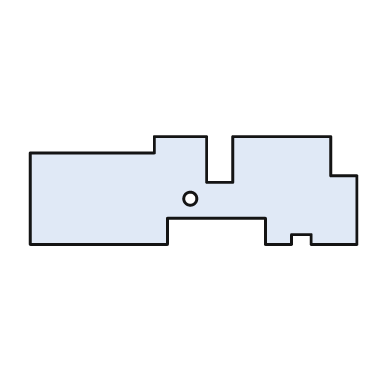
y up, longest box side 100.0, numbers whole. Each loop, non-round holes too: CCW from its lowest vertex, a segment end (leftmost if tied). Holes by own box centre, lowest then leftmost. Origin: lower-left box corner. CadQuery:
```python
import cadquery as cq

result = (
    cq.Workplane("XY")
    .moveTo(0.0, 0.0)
    .lineTo(42.0, 0.0)
    .lineTo(42.0, 8.0)
    .lineTo(72.0, 8.0)
    .lineTo(72.0, 0.0)
    .lineTo(80.0, 0.0)
    .lineTo(80.0, 3.0)
    .lineTo(86.0, 3.0)
    .lineTo(86.0, 0.0)
    .lineTo(100.0, 0.0)
    .lineTo(100.0, 21.0)
    .lineTo(92.0, 21.0)
    .lineTo(92.0, 33.0)
    .lineTo(62.0, 33.0)
    .lineTo(62.0, 19.0)
    .lineTo(54.0, 19.0)
    .lineTo(54.0, 33.0)
    .lineTo(38.0, 33.0)
    .lineTo(38.0, 28.0)
    .lineTo(0.0, 28.0)
    .close()
    .moveTo(49.0, 14.0)
    .circle(2.0)
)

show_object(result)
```